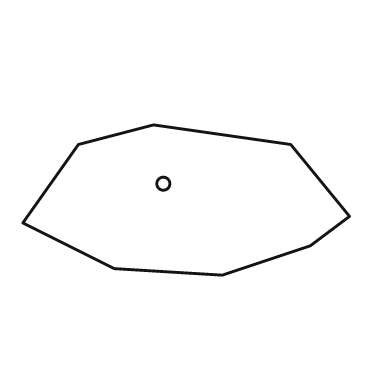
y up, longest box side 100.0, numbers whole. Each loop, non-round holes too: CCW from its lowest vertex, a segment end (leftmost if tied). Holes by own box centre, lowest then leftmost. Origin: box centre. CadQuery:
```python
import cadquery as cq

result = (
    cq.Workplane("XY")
    .moveTo(11.0, -23.0)
    .lineTo(38.0, -14.0)
    .lineTo(50.0, -5.0)
    .lineTo(32.0, 17.0)
    .lineTo(-10.0, 23.0)
    .lineTo(-33.0, 17.0)
    .lineTo(-50.0, -7.0)
    .lineTo(-22.0, -21.0)
    .close()
    .moveTo(-7.0, 5.0)
    .circle(2.0)
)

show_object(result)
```